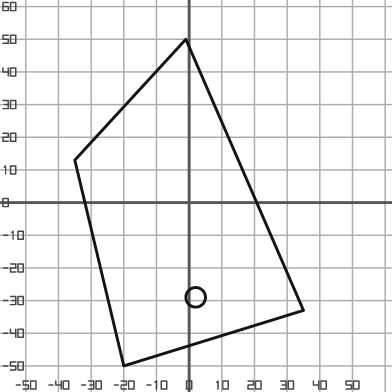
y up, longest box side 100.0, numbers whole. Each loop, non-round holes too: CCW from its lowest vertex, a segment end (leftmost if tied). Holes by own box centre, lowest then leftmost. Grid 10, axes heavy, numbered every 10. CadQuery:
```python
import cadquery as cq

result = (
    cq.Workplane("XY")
    .moveTo(-20.0, -50.0)
    .lineTo(35.0, -33.0)
    .lineTo(-1.0, 50.0)
    .lineTo(-35.0, 13.0)
    .close()
    .moveTo(2.0, -29.0)
    .circle(3.0)
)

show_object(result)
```